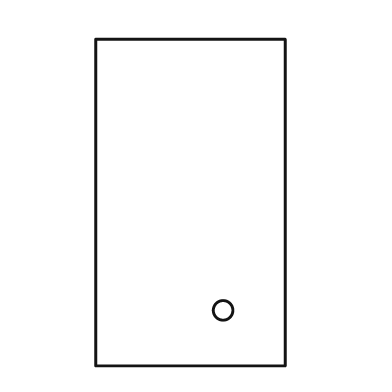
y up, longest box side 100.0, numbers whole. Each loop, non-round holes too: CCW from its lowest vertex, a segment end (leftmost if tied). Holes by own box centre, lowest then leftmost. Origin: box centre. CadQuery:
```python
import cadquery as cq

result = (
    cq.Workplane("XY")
    .moveTo(-29.0, -50.0)
    .lineTo(29.0, -50.0)
    .lineTo(29.0, 50.0)
    .lineTo(-29.0, 50.0)
    .close()
    .moveTo(10.0, -33.0)
    .circle(3.0)
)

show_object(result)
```